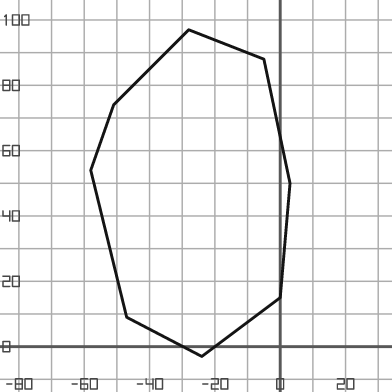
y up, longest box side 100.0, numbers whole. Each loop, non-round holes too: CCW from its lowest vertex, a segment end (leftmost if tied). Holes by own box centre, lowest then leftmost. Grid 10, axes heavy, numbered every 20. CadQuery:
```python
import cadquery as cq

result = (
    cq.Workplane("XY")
    .moveTo(-24.0, -3.0)
    .lineTo(0.0, 15.0)
    .lineTo(3.0, 50.0)
    .lineTo(-5.0, 88.0)
    .lineTo(-28.0, 97.0)
    .lineTo(-51.0, 74.0)
    .lineTo(-58.0, 54.0)
    .lineTo(-47.0, 9.0)
    .close()
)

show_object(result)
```